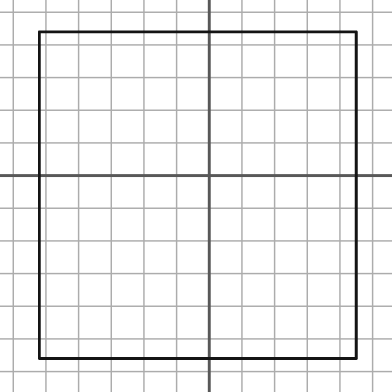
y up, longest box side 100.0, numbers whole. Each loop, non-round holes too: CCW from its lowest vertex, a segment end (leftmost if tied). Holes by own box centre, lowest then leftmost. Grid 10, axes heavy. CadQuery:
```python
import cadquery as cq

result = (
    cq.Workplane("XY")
    .moveTo(-52.0, -56.0)
    .lineTo(45.0, -56.0)
    .lineTo(45.0, 44.0)
    .lineTo(-52.0, 44.0)
    .close()
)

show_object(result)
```